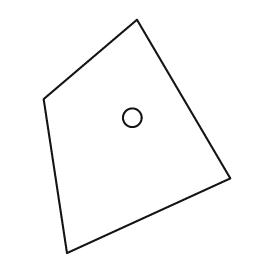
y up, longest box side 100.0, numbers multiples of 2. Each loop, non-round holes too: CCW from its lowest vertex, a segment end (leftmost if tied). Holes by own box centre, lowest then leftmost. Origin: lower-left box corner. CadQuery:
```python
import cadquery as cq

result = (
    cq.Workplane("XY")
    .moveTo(10.0, 0.0)
    .lineTo(80.0, 32.0)
    .lineTo(40.0, 100.0)
    .lineTo(0.0, 66.0)
    .close()
    .moveTo(38.0, 58.0)
    .circle(4.0)
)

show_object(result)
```